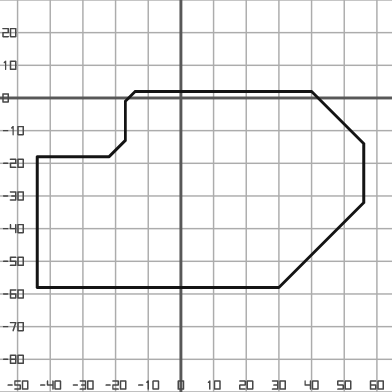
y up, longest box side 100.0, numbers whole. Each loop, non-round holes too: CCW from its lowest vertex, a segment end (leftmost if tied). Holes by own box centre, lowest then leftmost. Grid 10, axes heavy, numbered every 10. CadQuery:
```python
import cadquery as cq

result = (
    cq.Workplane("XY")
    .moveTo(-44.0, -58.0)
    .lineTo(30.0, -58.0)
    .lineTo(56.0, -32.0)
    .lineTo(56.0, -14.0)
    .lineTo(40.0, 2.0)
    .lineTo(-14.0, 2.0)
    .lineTo(-17.0, -1.0)
    .lineTo(-17.0, -13.0)
    .lineTo(-22.0, -18.0)
    .lineTo(-44.0, -18.0)
    .close()
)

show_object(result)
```